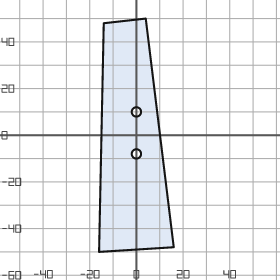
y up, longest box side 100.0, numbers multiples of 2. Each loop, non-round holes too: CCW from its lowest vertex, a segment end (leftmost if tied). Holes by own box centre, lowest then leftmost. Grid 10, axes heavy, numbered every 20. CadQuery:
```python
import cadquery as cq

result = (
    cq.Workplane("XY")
    .moveTo(-16.0, -50.0)
    .lineTo(16.0, -48.0)
    .lineTo(4.0, 50.0)
    .lineTo(-14.0, 48.0)
    .close()
    .moveTo(0.0, -8.0)
    .circle(2.0)
    .moveTo(0.0, 10.0)
    .circle(2.0)
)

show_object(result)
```